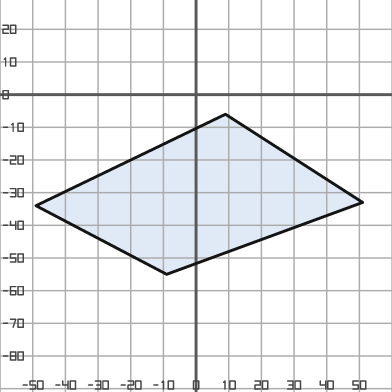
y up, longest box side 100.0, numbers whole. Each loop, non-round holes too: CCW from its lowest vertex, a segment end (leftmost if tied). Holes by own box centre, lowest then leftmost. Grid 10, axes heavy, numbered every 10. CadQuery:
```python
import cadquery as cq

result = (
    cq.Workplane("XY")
    .moveTo(-9.0, -55.0)
    .lineTo(51.0, -33.0)
    .lineTo(9.0, -6.0)
    .lineTo(-49.0, -34.0)
    .close()
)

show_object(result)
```